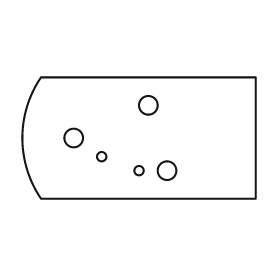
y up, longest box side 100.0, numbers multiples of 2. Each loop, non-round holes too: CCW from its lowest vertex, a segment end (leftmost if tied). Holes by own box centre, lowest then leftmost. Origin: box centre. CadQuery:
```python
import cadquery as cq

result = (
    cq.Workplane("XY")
    .moveTo(-42.0, -26.0)
    .lineTo(50.0, -26.0)
    .lineTo(50.0, 26.0)
    .lineTo(-42.0, 26.0)
    .threePointArc((-50.0, 0.0), (-42.0, -26.0))
    .close()
    .moveTo(0.0, -14.0)
    .circle(2.0)
    .moveTo(12.0, -14.0)
    .circle(4.0)
    .moveTo(-16.0, -8.0)
    .circle(2.0)
    .moveTo(-28.0, 0.0)
    .circle(4.0)
    .moveTo(4.0, 14.0)
    .circle(4.0)
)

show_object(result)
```